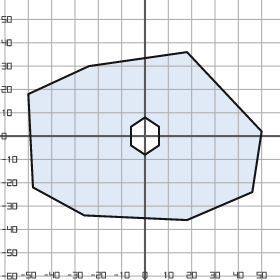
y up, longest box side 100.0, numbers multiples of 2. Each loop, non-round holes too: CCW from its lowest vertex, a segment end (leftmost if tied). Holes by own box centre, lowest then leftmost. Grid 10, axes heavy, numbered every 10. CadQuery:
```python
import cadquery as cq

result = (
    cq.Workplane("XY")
    .moveTo(18.0, -36.0)
    .lineTo(46.0, -24.0)
    .lineTo(50.0, 2.0)
    .lineTo(18.0, 36.0)
    .lineTo(-24.0, 30.0)
    .lineTo(-50.0, 18.0)
    .lineTo(-48.0, -22.0)
    .lineTo(-26.0, -34.0)
    .close()
    .moveTo(0.0, -8.0)
    .lineTo(6.0, -4.0)
    .lineTo(6.0, 4.0)
    .lineTo(0.0, 8.0)
    .lineTo(-6.0, 4.0)
    .lineTo(-6.0, -4.0)
    .close()
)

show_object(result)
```